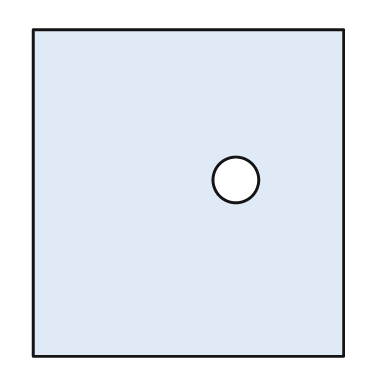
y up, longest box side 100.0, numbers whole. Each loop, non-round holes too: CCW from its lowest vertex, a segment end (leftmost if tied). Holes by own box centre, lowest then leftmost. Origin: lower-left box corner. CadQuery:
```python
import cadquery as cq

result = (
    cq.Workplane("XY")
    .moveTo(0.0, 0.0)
    .lineTo(95.0, 0.0)
    .lineTo(95.0, 100.0)
    .lineTo(0.0, 100.0)
    .close()
    .moveTo(62.0, 54.0)
    .circle(7.0)
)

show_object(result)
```